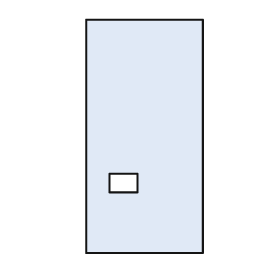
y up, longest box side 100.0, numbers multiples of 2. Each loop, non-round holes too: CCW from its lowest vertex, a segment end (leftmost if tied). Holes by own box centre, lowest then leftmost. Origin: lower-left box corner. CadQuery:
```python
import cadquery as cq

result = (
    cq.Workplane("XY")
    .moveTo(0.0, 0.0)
    .lineTo(50.0, 0.0)
    .lineTo(50.0, 100.0)
    .lineTo(0.0, 100.0)
    .close()
    .moveTo(10.0, 26.0)
    .lineTo(22.0, 26.0)
    .lineTo(22.0, 34.0)
    .lineTo(10.0, 34.0)
    .close()
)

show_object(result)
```